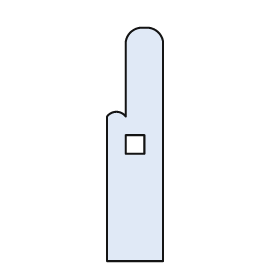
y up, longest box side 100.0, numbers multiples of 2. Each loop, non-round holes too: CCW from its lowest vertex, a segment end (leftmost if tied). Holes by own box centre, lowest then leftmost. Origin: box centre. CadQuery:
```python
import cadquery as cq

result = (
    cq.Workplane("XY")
    .moveTo(-12.0, -50.0)
    .lineTo(12.0, -50.0)
    .lineTo(12.0, 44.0)
    .threePointArc((10.0, 48.0), (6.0, 50.0))
    .lineTo(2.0, 50.0)
    .threePointArc((-2.0, 48.0), (-4.0, 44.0))
    .lineTo(-4.0, 12.0)
    .threePointArc((-8.0, 14.0), (-12.0, 12.0))
    .close()
    .moveTo(-4.0, -4.0)
    .lineTo(4.0, -4.0)
    .lineTo(4.0, 4.0)
    .lineTo(-4.0, 4.0)
    .close()
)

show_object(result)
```